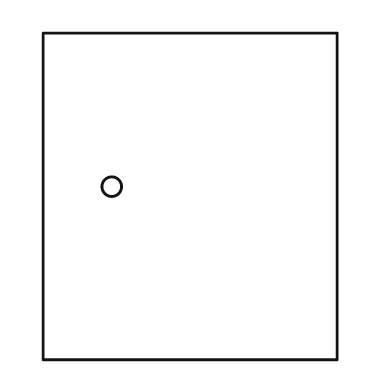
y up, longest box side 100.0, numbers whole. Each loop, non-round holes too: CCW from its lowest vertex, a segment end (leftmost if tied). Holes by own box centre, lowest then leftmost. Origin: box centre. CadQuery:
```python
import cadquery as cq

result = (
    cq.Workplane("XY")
    .moveTo(-45.0, -50.0)
    .lineTo(45.0, -50.0)
    .lineTo(45.0, 50.0)
    .lineTo(-45.0, 50.0)
    .close()
    .moveTo(-24.0, 3.0)
    .circle(3.0)
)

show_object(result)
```